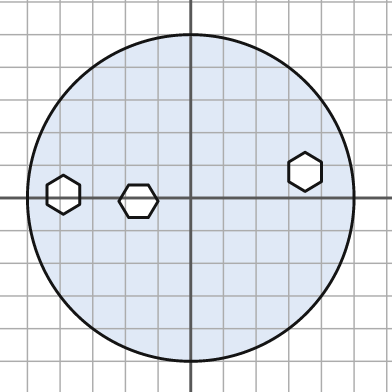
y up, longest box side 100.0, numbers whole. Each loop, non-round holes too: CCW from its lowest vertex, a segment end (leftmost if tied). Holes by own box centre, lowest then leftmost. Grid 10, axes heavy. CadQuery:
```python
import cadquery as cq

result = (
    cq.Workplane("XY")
    .moveTo(0.0, 0.0)
    .circle(50.0)
    .moveTo(-19.0, -6.0)
    .lineTo(-13.0, -6.0)
    .lineTo(-10.0, -1.0)
    .lineTo(-13.0, 4.0)
    .lineTo(-19.0, 4.0)
    .lineTo(-22.0, -1.0)
    .close()
    .moveTo(-39.0, -5.0)
    .lineTo(-34.0, -2.0)
    .lineTo(-34.0, 4.0)
    .lineTo(-39.0, 7.0)
    .lineTo(-44.0, 4.0)
    .lineTo(-44.0, -2.0)
    .close()
    .moveTo(35.0, 2.0)
    .lineTo(40.0, 5.0)
    .lineTo(40.0, 11.0)
    .lineTo(35.0, 14.0)
    .lineTo(30.0, 11.0)
    .lineTo(30.0, 5.0)
    .close()
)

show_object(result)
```